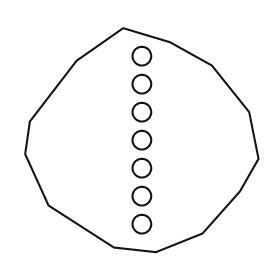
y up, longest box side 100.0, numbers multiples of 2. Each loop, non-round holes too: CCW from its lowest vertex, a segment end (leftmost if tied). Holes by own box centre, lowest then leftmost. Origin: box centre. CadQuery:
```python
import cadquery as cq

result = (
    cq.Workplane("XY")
    .moveTo(6.0, -48.0)
    .lineTo(26.0, -40.0)
    .lineTo(42.0, -22.0)
    .lineTo(50.0, -8.0)
    .lineTo(46.0, 12.0)
    .lineTo(30.0, 32.0)
    .lineTo(12.0, 42.0)
    .lineTo(-8.0, 48.0)
    .lineTo(-28.0, 34.0)
    .lineTo(-48.0, 8.0)
    .lineTo(-50.0, -6.0)
    .lineTo(-40.0, -28.0)
    .lineTo(-12.0, -46.0)
    .close()
    .moveTo(0.0, -36.0)
    .circle(4.0)
    .moveTo(0.0, -24.0)
    .circle(4.0)
    .moveTo(0.0, -12.0)
    .circle(4.0)
    .moveTo(0.0, 0.0)
    .circle(4.0)
    .moveTo(0.0, 12.0)
    .circle(4.0)
    .moveTo(0.0, 24.0)
    .circle(4.0)
    .moveTo(0.0, 36.0)
    .circle(4.0)
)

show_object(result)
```